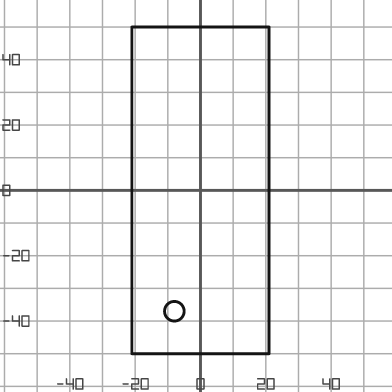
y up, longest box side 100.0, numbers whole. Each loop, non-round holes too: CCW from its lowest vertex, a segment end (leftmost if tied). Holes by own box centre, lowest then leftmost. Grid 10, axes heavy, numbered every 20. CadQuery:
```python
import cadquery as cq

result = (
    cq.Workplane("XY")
    .moveTo(-21.0, -50.0)
    .lineTo(21.0, -50.0)
    .lineTo(21.0, 50.0)
    .lineTo(-21.0, 50.0)
    .close()
    .moveTo(-8.0, -37.0)
    .circle(3.0)
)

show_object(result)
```